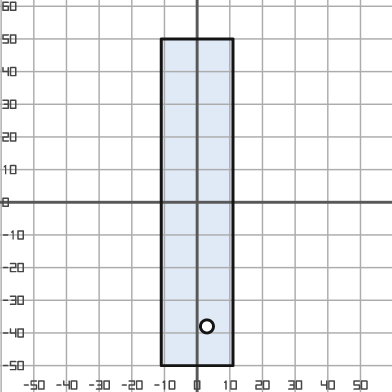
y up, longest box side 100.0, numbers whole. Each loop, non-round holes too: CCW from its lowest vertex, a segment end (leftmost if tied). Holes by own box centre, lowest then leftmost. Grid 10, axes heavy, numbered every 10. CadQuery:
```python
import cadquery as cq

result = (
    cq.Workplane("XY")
    .moveTo(-11.0, -50.0)
    .lineTo(11.0, -50.0)
    .lineTo(11.0, 50.0)
    .lineTo(-11.0, 50.0)
    .close()
    .moveTo(3.0, -38.0)
    .circle(2.0)
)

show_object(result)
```